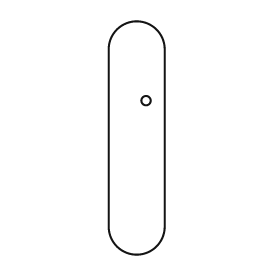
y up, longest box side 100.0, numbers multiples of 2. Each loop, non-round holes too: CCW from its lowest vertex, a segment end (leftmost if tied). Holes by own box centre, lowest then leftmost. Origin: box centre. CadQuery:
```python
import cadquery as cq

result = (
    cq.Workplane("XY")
    .moveTo(-12.0, -38.0)
    .threePointArc((0.0, -50.0), (12.0, -38.0))
    .lineTo(12.0, 38.0)
    .threePointArc((0.0, 50.0), (-12.0, 38.0))
    .close()
    .moveTo(4.0, 16.0)
    .circle(2.0)
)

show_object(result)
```